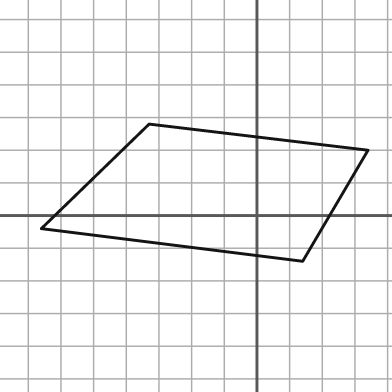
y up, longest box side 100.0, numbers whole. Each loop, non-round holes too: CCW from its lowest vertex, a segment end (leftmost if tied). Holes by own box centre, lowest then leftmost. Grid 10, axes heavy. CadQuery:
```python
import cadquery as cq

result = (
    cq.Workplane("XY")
    .moveTo(14.0, -14.0)
    .lineTo(34.0, 20.0)
    .lineTo(-33.0, 28.0)
    .lineTo(-66.0, -4.0)
    .close()
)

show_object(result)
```